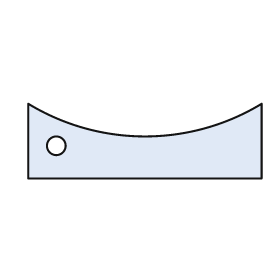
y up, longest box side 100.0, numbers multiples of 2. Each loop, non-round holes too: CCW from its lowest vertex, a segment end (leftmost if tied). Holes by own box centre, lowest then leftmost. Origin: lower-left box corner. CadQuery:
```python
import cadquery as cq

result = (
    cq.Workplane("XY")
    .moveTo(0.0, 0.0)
    .lineTo(100.0, 0.0)
    .lineTo(100.0, 32.0)
    .threePointArc((50.0, 18.0), (0.0, 32.0))
    .close()
    .moveTo(12.0, 14.0)
    .circle(4.0)
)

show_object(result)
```